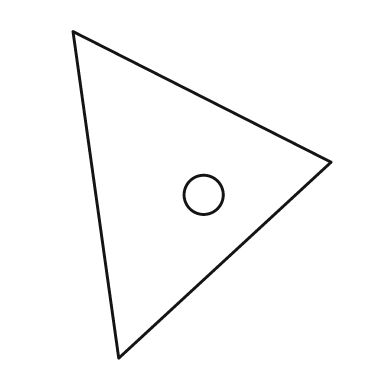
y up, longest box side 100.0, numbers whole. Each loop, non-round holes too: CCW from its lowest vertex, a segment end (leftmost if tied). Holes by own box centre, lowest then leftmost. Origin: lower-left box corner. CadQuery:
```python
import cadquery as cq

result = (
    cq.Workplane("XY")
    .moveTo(14.0, 0.0)
    .lineTo(79.0, 60.0)
    .lineTo(0.0, 100.0)
    .close()
    .moveTo(40.0, 50.0)
    .circle(6.0)
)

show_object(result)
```